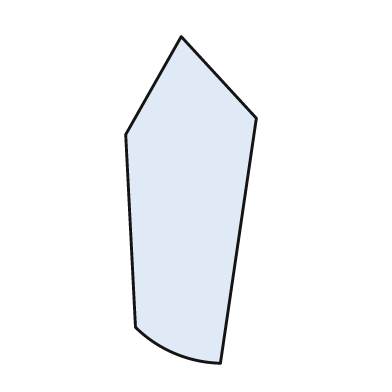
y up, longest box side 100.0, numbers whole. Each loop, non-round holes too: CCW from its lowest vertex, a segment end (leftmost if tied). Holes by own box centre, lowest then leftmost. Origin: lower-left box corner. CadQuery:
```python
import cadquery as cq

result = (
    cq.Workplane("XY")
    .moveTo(29.0, 0.0)
    .lineTo(40.0, 75.0)
    .lineTo(17.0, 100.0)
    .lineTo(0.0, 70.0)
    .lineTo(3.0, 11.0)
    .threePointArc((15.0, 3.0), (29.0, 0.0))
    .close()
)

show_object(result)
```